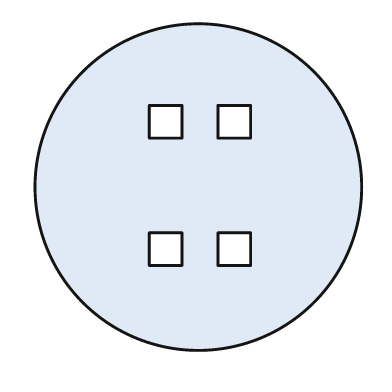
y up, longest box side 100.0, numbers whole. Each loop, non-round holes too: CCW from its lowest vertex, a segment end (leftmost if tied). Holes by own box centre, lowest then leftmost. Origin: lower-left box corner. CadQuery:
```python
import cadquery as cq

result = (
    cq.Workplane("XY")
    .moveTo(50.0, 50.0)
    .circle(50.0)
    .moveTo(35.0, 26.0)
    .lineTo(45.0, 26.0)
    .lineTo(45.0, 36.0)
    .lineTo(35.0, 36.0)
    .close()
    .moveTo(56.0, 26.0)
    .lineTo(66.0, 26.0)
    .lineTo(66.0, 36.0)
    .lineTo(56.0, 36.0)
    .close()
    .moveTo(35.0, 65.0)
    .lineTo(45.0, 65.0)
    .lineTo(45.0, 75.0)
    .lineTo(35.0, 75.0)
    .close()
    .moveTo(56.0, 65.0)
    .lineTo(66.0, 65.0)
    .lineTo(66.0, 75.0)
    .lineTo(56.0, 75.0)
    .close()
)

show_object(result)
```